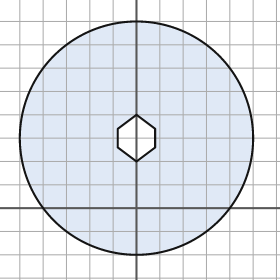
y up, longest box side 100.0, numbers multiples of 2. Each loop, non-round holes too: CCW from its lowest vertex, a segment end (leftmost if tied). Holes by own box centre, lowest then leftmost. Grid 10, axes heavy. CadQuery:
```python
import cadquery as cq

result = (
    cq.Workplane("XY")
    .moveTo(0.0, 30.0)
    .circle(50.0)
    .moveTo(0.0, 20.0)
    .lineTo(8.0, 26.0)
    .lineTo(8.0, 34.0)
    .lineTo(0.0, 40.0)
    .lineTo(-8.0, 34.0)
    .lineTo(-8.0, 26.0)
    .close()
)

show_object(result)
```